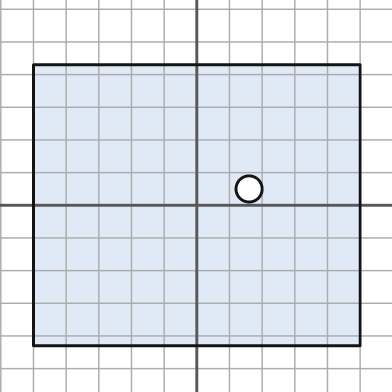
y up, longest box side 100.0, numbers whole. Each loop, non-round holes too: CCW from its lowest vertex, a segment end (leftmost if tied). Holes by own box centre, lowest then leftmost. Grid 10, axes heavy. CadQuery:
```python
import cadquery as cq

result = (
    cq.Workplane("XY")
    .moveTo(-50.0, -43.0)
    .lineTo(50.0, -43.0)
    .lineTo(50.0, 43.0)
    .lineTo(-50.0, 43.0)
    .close()
    .moveTo(16.0, 5.0)
    .circle(4.0)
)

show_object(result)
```